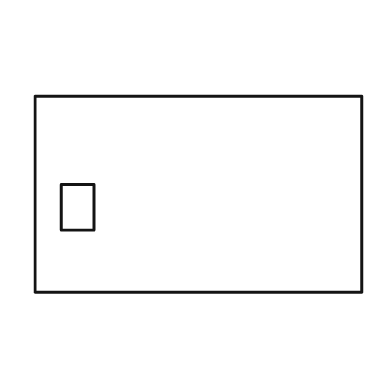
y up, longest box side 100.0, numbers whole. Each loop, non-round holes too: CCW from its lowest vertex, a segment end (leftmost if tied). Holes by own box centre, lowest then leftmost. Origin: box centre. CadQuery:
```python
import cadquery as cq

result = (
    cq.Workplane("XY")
    .moveTo(-50.0, -30.0)
    .lineTo(50.0, -30.0)
    .lineTo(50.0, 30.0)
    .lineTo(-50.0, 30.0)
    .close()
    .moveTo(-42.0, -11.0)
    .lineTo(-32.0, -11.0)
    .lineTo(-32.0, 3.0)
    .lineTo(-42.0, 3.0)
    .close()
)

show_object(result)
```